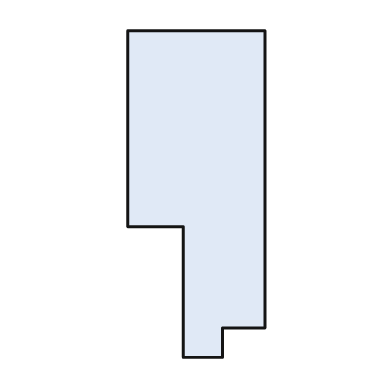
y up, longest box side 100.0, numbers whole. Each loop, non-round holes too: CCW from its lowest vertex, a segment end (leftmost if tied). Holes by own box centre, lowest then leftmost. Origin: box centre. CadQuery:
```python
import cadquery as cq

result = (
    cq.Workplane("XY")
    .moveTo(-4.0, -50.0)
    .lineTo(8.0, -50.0)
    .lineTo(8.0, -41.0)
    .lineTo(21.0, -41.0)
    .lineTo(21.0, 50.0)
    .lineTo(-21.0, 50.0)
    .lineTo(-21.0, -10.0)
    .lineTo(-4.0, -10.0)
    .close()
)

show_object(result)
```